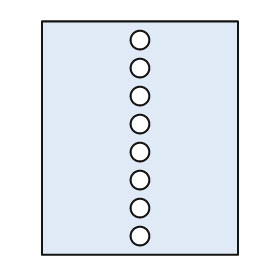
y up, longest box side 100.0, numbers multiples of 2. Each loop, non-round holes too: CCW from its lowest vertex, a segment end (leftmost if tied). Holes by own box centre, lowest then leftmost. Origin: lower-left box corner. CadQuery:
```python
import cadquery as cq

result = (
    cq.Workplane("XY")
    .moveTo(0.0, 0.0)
    .lineTo(84.0, 0.0)
    .lineTo(84.0, 100.0)
    .lineTo(0.0, 100.0)
    .close()
    .moveTo(42.0, 8.0)
    .circle(4.0)
    .moveTo(42.0, 20.0)
    .circle(4.0)
    .moveTo(42.0, 32.0)
    .circle(4.0)
    .moveTo(42.0, 44.0)
    .circle(4.0)
    .moveTo(42.0, 56.0)
    .circle(4.0)
    .moveTo(42.0, 68.0)
    .circle(4.0)
    .moveTo(42.0, 80.0)
    .circle(4.0)
    .moveTo(42.0, 92.0)
    .circle(4.0)
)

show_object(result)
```